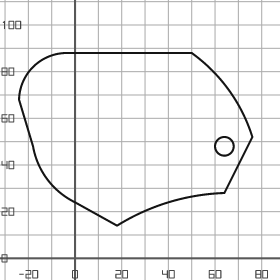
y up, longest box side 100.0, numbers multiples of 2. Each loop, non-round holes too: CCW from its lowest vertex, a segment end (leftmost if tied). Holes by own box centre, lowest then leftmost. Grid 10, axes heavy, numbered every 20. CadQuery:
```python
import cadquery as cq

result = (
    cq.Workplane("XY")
    .moveTo(18.0, 14.0)
    .threePointArc((40.0, 24.0), (64.0, 28.0))
    .lineTo(76.0, 52.0)
    .threePointArc((66.0, 72.0), (50.0, 88.0))
    .lineTo(-4.0, 88.0)
    .threePointArc((-18.0, 82.0), (-24.0, 68.0))
    .lineTo(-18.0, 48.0)
    .threePointArc((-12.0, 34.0), (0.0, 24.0))
    .close()
    .moveTo(64.0, 48.0)
    .circle(4.0)
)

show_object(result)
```